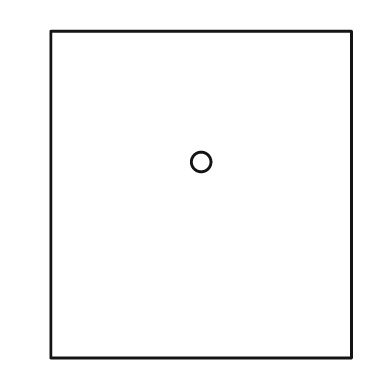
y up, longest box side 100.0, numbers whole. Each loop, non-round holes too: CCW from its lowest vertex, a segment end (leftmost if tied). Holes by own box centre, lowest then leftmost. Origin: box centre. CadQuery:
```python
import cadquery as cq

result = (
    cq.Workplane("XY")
    .moveTo(-46.0, -50.0)
    .lineTo(46.0, -50.0)
    .lineTo(46.0, 50.0)
    .lineTo(-46.0, 50.0)
    .close()
    .moveTo(0.0, 10.0)
    .circle(3.0)
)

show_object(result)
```